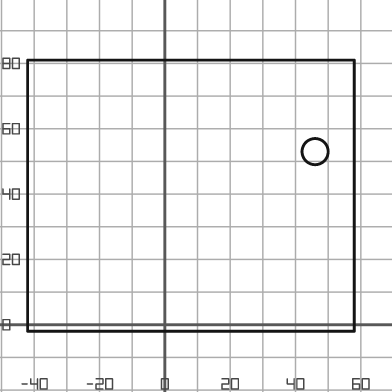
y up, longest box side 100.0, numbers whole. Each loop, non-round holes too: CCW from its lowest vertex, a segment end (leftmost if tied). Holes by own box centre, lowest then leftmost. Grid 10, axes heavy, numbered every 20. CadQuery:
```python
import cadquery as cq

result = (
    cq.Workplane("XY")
    .moveTo(-42.0, -2.0)
    .lineTo(58.0, -2.0)
    .lineTo(58.0, 81.0)
    .lineTo(-42.0, 81.0)
    .close()
    .moveTo(46.0, 53.0)
    .circle(4.0)
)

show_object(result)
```